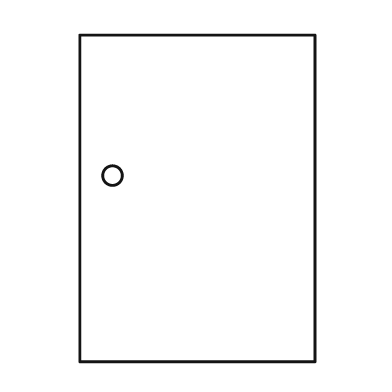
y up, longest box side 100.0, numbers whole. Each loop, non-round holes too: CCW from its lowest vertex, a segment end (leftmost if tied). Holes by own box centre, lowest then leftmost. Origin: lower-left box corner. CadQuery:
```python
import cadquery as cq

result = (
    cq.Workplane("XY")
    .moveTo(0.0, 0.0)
    .lineTo(72.0, 0.0)
    .lineTo(72.0, 100.0)
    .lineTo(0.0, 100.0)
    .close()
    .moveTo(10.0, 57.0)
    .circle(3.0)
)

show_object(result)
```